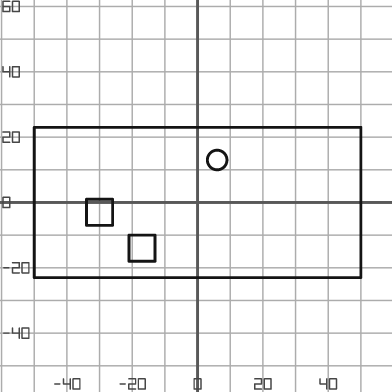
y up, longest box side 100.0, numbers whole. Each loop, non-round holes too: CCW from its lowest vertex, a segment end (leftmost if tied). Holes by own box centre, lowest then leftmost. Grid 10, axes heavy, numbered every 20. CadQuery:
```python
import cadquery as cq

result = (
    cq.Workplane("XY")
    .moveTo(-50.0, -23.0)
    .lineTo(50.0, -23.0)
    .lineTo(50.0, 23.0)
    .lineTo(-50.0, 23.0)
    .close()
    .moveTo(-21.0, -18.0)
    .lineTo(-13.0, -18.0)
    .lineTo(-13.0, -10.0)
    .lineTo(-21.0, -10.0)
    .close()
    .moveTo(-34.0, -7.0)
    .lineTo(-26.0, -7.0)
    .lineTo(-26.0, 1.0)
    .lineTo(-34.0, 1.0)
    .close()
    .moveTo(6.0, 13.0)
    .circle(3.0)
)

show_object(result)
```